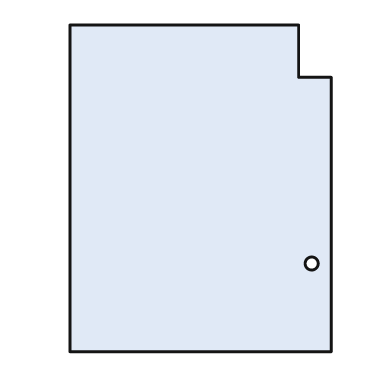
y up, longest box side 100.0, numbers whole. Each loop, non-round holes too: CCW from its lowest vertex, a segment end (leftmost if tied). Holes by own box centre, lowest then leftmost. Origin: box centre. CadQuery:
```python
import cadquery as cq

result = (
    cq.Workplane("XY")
    .moveTo(-40.0, -50.0)
    .lineTo(40.0, -50.0)
    .lineTo(40.0, 34.0)
    .lineTo(30.0, 34.0)
    .lineTo(30.0, 50.0)
    .lineTo(-40.0, 50.0)
    .close()
    .moveTo(34.0, -23.0)
    .circle(2.0)
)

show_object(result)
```